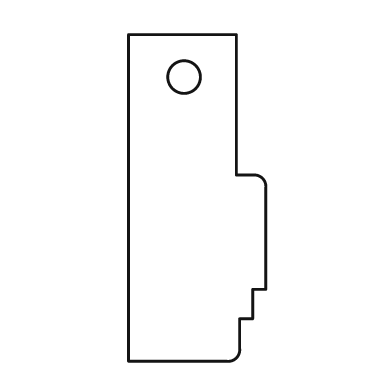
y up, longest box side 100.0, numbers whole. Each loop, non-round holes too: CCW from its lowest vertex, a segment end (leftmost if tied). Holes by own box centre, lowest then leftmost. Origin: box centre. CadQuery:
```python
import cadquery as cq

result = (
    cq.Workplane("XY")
    .moveTo(-21.0, -50.0)
    .lineTo(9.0, -50.0)
    .threePointArc((12.0, -49.0), (13.0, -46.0))
    .lineTo(13.0, -37.0)
    .lineTo(17.0, -37.0)
    .lineTo(17.0, -28.0)
    .lineTo(21.0, -28.0)
    .lineTo(21.0, 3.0)
    .threePointArc((20.0, 6.0), (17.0, 7.0))
    .lineTo(12.0, 7.0)
    .lineTo(12.0, 50.0)
    .lineTo(-21.0, 50.0)
    .close()
    .moveTo(-4.0, 37.0)
    .circle(5.0)
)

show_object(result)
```